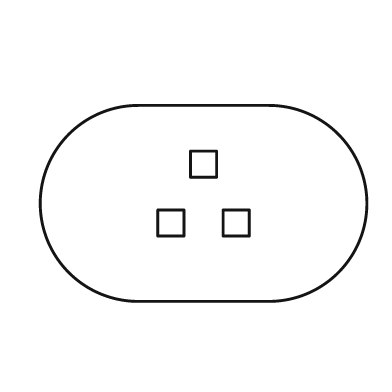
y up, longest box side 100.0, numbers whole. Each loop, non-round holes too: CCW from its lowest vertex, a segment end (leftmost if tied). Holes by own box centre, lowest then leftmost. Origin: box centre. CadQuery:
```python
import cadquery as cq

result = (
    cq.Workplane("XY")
    .moveTo(-20.0, -30.0)
    .lineTo(20.0, -30.0)
    .threePointArc((50.0, 0.0), (20.0, 30.0))
    .lineTo(-20.0, 30.0)
    .threePointArc((-50.0, 0.0), (-20.0, -30.0))
    .close()
    .moveTo(-14.0, -10.0)
    .lineTo(-6.0, -10.0)
    .lineTo(-6.0, -2.0)
    .lineTo(-14.0, -2.0)
    .close()
    .moveTo(6.0, -10.0)
    .lineTo(14.0, -10.0)
    .lineTo(14.0, -2.0)
    .lineTo(6.0, -2.0)
    .close()
    .moveTo(-4.0, 8.0)
    .lineTo(4.0, 8.0)
    .lineTo(4.0, 16.0)
    .lineTo(-4.0, 16.0)
    .close()
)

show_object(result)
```